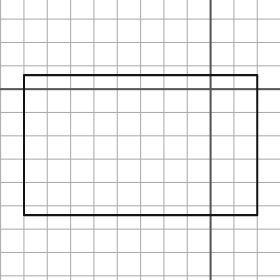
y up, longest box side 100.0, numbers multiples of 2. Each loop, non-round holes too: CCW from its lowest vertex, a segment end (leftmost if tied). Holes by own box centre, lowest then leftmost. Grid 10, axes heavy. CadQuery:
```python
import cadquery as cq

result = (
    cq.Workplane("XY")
    .moveTo(-80.0, -54.0)
    .lineTo(20.0, -54.0)
    .lineTo(20.0, 6.0)
    .lineTo(-80.0, 6.0)
    .close()
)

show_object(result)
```